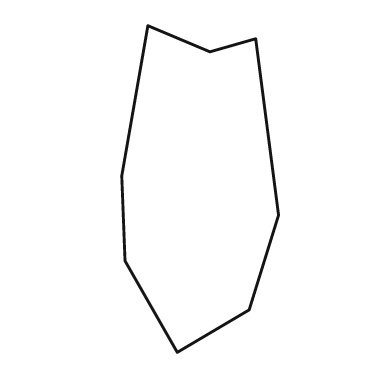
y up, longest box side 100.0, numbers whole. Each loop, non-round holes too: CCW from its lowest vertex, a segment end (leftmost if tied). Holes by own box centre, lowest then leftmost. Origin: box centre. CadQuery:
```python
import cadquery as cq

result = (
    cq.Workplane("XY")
    .moveTo(-7.0, -50.0)
    .lineTo(15.0, -37.0)
    .lineTo(24.0, -8.0)
    .lineTo(17.0, 46.0)
    .lineTo(3.0, 42.0)
    .lineTo(-16.0, 50.0)
    .lineTo(-24.0, 4.0)
    .lineTo(-23.0, -22.0)
    .close()
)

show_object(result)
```